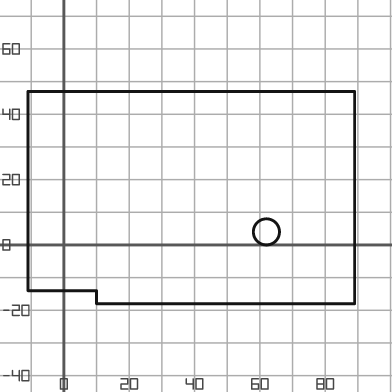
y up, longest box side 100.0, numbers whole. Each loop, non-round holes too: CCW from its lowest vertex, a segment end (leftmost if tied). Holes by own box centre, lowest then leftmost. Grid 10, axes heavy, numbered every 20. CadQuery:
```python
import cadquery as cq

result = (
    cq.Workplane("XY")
    .moveTo(10.0, -18.0)
    .lineTo(89.0, -18.0)
    .lineTo(89.0, 47.0)
    .lineTo(-11.0, 47.0)
    .lineTo(-11.0, -14.0)
    .lineTo(10.0, -14.0)
    .close()
    .moveTo(62.0, 4.0)
    .circle(4.0)
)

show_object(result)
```